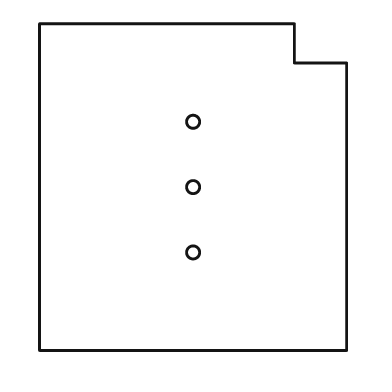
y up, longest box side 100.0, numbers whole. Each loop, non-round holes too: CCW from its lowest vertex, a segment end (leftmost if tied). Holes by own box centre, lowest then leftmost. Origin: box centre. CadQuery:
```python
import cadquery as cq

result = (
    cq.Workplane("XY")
    .moveTo(-47.0, -50.0)
    .lineTo(47.0, -50.0)
    .lineTo(47.0, 38.0)
    .lineTo(31.0, 38.0)
    .lineTo(31.0, 50.0)
    .lineTo(-47.0, 50.0)
    .close()
    .moveTo(0.0, -20.0)
    .circle(2.0)
    .moveTo(0.0, 0.0)
    .circle(2.0)
    .moveTo(0.0, 20.0)
    .circle(2.0)
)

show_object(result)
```